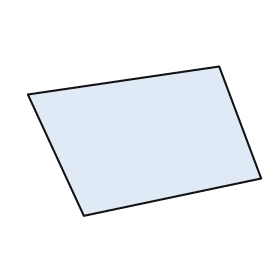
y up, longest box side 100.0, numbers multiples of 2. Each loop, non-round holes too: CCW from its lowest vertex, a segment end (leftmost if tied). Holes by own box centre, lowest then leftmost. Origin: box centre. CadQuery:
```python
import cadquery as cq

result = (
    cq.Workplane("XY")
    .moveTo(-26.0, -32.0)
    .lineTo(50.0, -16.0)
    .lineTo(32.0, 32.0)
    .lineTo(-50.0, 20.0)
    .close()
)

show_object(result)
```